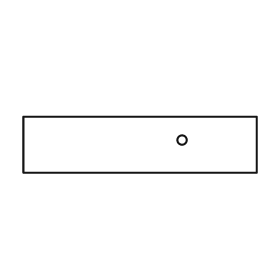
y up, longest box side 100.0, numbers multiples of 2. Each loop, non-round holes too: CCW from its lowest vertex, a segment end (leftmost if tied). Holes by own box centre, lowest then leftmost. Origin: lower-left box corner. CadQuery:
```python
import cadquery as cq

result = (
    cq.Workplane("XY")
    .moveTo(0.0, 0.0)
    .lineTo(100.0, 0.0)
    .lineTo(100.0, 24.0)
    .lineTo(0.0, 24.0)
    .close()
    .moveTo(68.0, 14.0)
    .circle(2.0)
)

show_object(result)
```